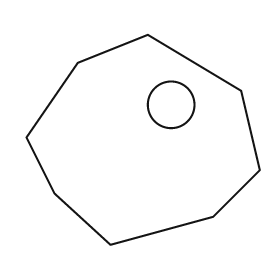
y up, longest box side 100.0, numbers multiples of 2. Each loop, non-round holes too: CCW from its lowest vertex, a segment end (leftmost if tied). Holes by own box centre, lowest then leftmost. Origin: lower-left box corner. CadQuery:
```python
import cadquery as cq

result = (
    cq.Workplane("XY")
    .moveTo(36.0, 0.0)
    .lineTo(80.0, 12.0)
    .lineTo(100.0, 32.0)
    .lineTo(92.0, 66.0)
    .lineTo(52.0, 90.0)
    .lineTo(22.0, 78.0)
    .lineTo(0.0, 46.0)
    .lineTo(12.0, 22.0)
    .close()
    .moveTo(62.0, 60.0)
    .circle(10.0)
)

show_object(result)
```